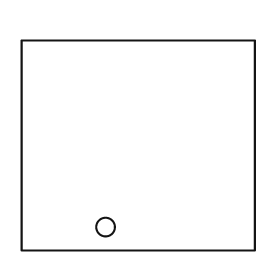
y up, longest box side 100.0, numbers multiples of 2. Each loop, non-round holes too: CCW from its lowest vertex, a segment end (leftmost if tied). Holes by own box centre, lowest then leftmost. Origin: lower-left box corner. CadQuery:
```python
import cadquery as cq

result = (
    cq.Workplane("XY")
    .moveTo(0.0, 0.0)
    .lineTo(100.0, 0.0)
    .lineTo(100.0, 90.0)
    .lineTo(0.0, 90.0)
    .close()
    .moveTo(36.0, 10.0)
    .circle(4.0)
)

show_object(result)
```